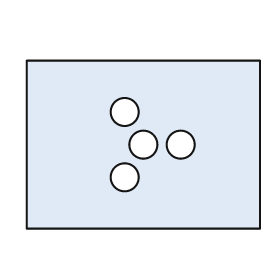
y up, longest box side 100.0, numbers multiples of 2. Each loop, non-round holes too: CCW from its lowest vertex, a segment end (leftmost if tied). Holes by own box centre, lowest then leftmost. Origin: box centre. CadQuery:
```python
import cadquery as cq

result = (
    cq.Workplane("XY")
    .moveTo(-50.0, -36.0)
    .lineTo(50.0, -36.0)
    .lineTo(50.0, 36.0)
    .lineTo(-50.0, 36.0)
    .close()
    .moveTo(-8.0, -14.0)
    .circle(6.0)
    .moveTo(0.0, 0.0)
    .circle(6.0)
    .moveTo(16.0, 0.0)
    .circle(6.0)
    .moveTo(-8.0, 14.0)
    .circle(6.0)
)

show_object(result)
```